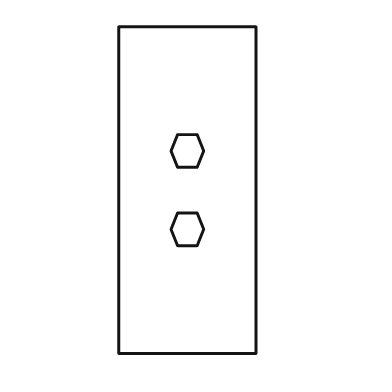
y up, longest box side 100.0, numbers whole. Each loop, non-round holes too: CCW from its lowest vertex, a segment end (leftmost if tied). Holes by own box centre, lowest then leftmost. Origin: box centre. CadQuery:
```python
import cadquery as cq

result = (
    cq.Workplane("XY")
    .moveTo(-21.0, -50.0)
    .lineTo(21.0, -50.0)
    .lineTo(21.0, 50.0)
    .lineTo(-21.0, 50.0)
    .close()
    .moveTo(-3.0, -17.0)
    .lineTo(3.0, -17.0)
    .lineTo(5.0, -12.0)
    .lineTo(3.0, -7.0)
    .lineTo(-3.0, -7.0)
    .lineTo(-5.0, -12.0)
    .close()
    .moveTo(-3.0, 7.0)
    .lineTo(3.0, 7.0)
    .lineTo(5.0, 12.0)
    .lineTo(3.0, 17.0)
    .lineTo(-3.0, 17.0)
    .lineTo(-5.0, 12.0)
    .close()
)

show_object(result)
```